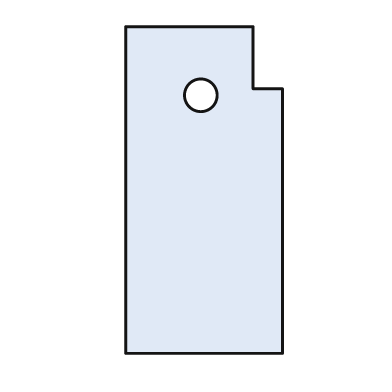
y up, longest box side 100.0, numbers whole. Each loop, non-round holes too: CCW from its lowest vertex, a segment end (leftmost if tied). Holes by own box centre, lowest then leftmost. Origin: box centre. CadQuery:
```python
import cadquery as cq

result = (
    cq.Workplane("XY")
    .moveTo(-24.0, -50.0)
    .lineTo(24.0, -50.0)
    .lineTo(24.0, 31.0)
    .lineTo(15.0, 31.0)
    .lineTo(15.0, 50.0)
    .lineTo(-24.0, 50.0)
    .close()
    .moveTo(-1.0, 29.0)
    .circle(5.0)
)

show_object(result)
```